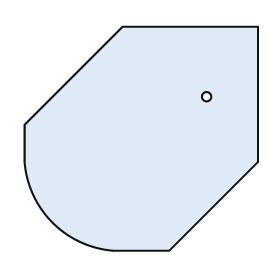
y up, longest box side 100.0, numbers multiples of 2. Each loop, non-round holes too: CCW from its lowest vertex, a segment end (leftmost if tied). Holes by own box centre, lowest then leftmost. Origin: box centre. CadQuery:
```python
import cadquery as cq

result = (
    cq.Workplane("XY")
    .moveTo(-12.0, -48.0)
    .lineTo(12.0, -48.0)
    .lineTo(50.0, -10.0)
    .lineTo(50.0, 48.0)
    .lineTo(-8.0, 48.0)
    .lineTo(-50.0, 6.0)
    .lineTo(-50.0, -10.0)
    .threePointArc((-38.0, -36.0), (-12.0, -48.0))
    .close()
    .moveTo(28.0, 18.0)
    .circle(2.0)
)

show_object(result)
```